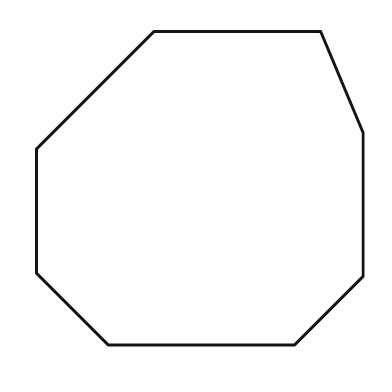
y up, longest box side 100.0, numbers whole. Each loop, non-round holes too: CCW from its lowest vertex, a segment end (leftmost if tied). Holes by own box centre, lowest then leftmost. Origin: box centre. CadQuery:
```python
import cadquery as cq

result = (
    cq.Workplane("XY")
    .moveTo(-28.0, -48.0)
    .lineTo(29.0, -48.0)
    .lineTo(50.0, -27.0)
    .lineTo(50.0, 17.0)
    .lineTo(37.0, 48.0)
    .lineTo(-14.0, 48.0)
    .lineTo(-50.0, 12.0)
    .lineTo(-50.0, -26.0)
    .close()
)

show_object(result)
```